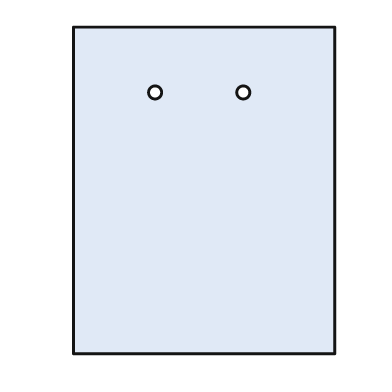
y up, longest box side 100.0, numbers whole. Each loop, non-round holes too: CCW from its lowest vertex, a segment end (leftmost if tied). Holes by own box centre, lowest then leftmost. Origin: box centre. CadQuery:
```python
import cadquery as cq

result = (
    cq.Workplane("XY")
    .moveTo(-40.0, -50.0)
    .lineTo(40.0, -50.0)
    .lineTo(40.0, 50.0)
    .lineTo(-40.0, 50.0)
    .close()
    .moveTo(-15.0, 30.0)
    .circle(2.0)
    .moveTo(12.0, 30.0)
    .circle(2.0)
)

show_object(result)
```